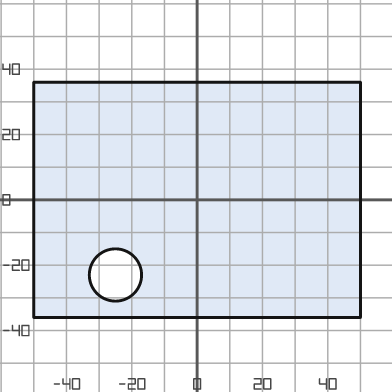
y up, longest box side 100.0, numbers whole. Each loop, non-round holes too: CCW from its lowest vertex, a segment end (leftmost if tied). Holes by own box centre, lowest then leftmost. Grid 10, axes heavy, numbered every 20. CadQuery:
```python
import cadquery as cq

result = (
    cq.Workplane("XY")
    .moveTo(-50.0, -36.0)
    .lineTo(50.0, -36.0)
    .lineTo(50.0, 36.0)
    .lineTo(-50.0, 36.0)
    .close()
    .moveTo(-25.0, -23.0)
    .circle(8.0)
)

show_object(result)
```